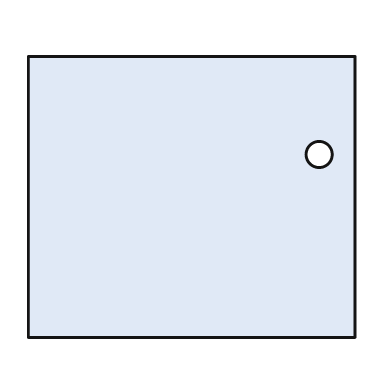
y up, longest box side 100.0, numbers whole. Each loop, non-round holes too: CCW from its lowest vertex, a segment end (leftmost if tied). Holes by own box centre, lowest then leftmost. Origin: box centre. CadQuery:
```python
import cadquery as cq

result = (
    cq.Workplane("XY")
    .moveTo(-50.0, -43.0)
    .lineTo(50.0, -43.0)
    .lineTo(50.0, 43.0)
    .lineTo(-50.0, 43.0)
    .close()
    .moveTo(39.0, 13.0)
    .circle(4.0)
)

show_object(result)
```